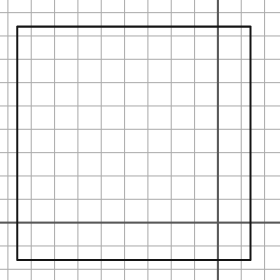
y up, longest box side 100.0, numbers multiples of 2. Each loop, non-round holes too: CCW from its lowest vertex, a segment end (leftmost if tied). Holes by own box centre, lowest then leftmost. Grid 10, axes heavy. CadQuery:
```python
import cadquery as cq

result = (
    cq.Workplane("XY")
    .moveTo(-86.0, -16.0)
    .lineTo(14.0, -16.0)
    .lineTo(14.0, 84.0)
    .lineTo(-86.0, 84.0)
    .close()
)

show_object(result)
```